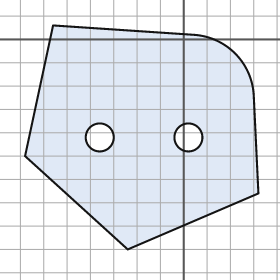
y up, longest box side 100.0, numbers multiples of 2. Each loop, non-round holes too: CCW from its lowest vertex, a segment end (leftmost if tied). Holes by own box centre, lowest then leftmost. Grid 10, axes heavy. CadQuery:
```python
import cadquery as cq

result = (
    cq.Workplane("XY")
    .moveTo(-24.0, -90.0)
    .lineTo(32.0, -66.0)
    .lineTo(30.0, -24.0)
    .threePointArc((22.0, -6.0), (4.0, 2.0))
    .lineTo(-56.0, 6.0)
    .lineTo(-68.0, -50.0)
    .close()
    .moveTo(-36.0, -42.0)
    .circle(6.0)
    .moveTo(2.0, -42.0)
    .circle(6.0)
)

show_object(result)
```